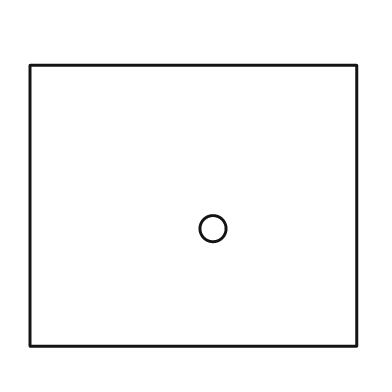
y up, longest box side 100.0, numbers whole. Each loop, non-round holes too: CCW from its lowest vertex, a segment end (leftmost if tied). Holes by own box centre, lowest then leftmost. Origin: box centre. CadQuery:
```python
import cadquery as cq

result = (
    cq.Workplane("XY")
    .moveTo(-50.0, -43.0)
    .lineTo(50.0, -43.0)
    .lineTo(50.0, 43.0)
    .lineTo(-50.0, 43.0)
    .close()
    .moveTo(6.0, -7.0)
    .circle(4.0)
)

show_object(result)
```